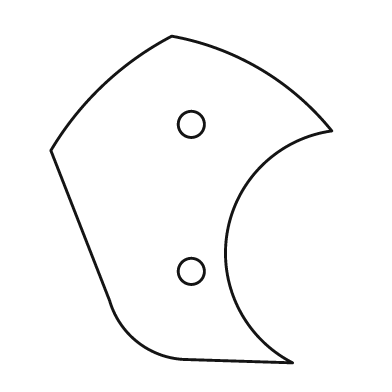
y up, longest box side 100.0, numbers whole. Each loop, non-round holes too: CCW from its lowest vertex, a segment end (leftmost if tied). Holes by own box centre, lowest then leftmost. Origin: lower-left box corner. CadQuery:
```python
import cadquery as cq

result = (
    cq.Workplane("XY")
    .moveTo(74.0, 0.0)
    .threePointArc((54.0, 40.0), (86.0, 71.0))
    .threePointArc((64.0, 90.0), (37.0, 100.0))
    .threePointArc((16.0, 85.0), (0.0, 65.0))
    .lineTo(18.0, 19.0)
    .threePointArc((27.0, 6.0), (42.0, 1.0))
    .close()
    .moveTo(43.0, 28.0)
    .circle(4.0)
    .moveTo(43.0, 73.0)
    .circle(4.0)
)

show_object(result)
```